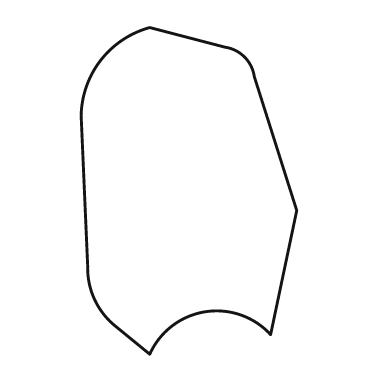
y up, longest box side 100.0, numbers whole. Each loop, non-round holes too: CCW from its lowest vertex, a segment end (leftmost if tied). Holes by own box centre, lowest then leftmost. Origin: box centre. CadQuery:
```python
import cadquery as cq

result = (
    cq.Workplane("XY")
    .moveTo(-12.0, -50.0)
    .threePointArc((5.0, -37.0), (25.0, -44.0))
    .lineTo(33.0, -6.0)
    .lineTo(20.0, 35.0)
    .threePointArc((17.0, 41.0), (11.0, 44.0))
    .lineTo(-12.0, 50.0)
    .threePointArc((-27.0, 40.0), (-33.0, 23.0))
    .lineTo(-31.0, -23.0)
    .threePointArc((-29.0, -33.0), (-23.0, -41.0))
    .close()
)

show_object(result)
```